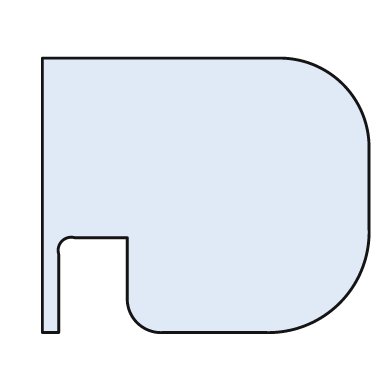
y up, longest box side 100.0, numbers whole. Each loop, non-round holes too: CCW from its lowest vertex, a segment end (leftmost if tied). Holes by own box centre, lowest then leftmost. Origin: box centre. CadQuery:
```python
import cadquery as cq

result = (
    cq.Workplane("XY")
    .moveTo(-50.0, -42.0)
    .lineTo(-45.0, -42.0)
    .lineTo(-45.0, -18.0)
    .threePointArc((-44.0, -14.0), (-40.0, -13.0))
    .lineTo(-24.0, -13.0)
    .lineTo(-24.0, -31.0)
    .threePointArc((-21.0, -39.0), (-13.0, -42.0))
    .lineTo(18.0, -42.0)
    .threePointArc((41.0, -33.0), (50.0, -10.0))
    .lineTo(50.0, 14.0)
    .threePointArc((42.0, 34.0), (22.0, 42.0))
    .lineTo(-50.0, 42.0)
    .close()
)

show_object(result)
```